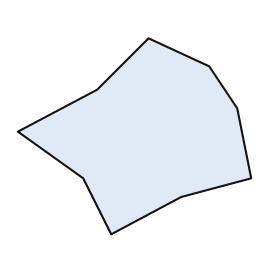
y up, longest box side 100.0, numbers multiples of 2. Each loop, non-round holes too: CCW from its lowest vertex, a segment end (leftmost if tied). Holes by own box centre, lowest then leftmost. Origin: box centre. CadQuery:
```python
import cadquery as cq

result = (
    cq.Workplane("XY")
    .moveTo(-10.0, -42.0)
    .lineTo(20.0, -26.0)
    .lineTo(50.0, -18.0)
    .lineTo(44.0, 12.0)
    .lineTo(32.0, 30.0)
    .lineTo(6.0, 42.0)
    .lineTo(-16.0, 20.0)
    .lineTo(-50.0, 2.0)
    .lineTo(-22.0, -18.0)
    .close()
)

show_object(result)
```